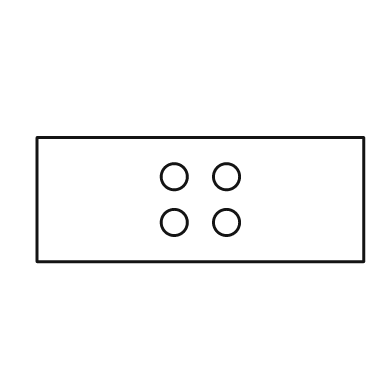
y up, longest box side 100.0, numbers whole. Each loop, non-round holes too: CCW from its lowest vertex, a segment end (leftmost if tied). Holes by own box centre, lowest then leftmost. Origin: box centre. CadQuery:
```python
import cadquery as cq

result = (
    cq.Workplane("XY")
    .moveTo(-50.0, -19.0)
    .lineTo(50.0, -19.0)
    .lineTo(50.0, 19.0)
    .lineTo(-50.0, 19.0)
    .close()
    .moveTo(-8.0, -7.0)
    .circle(4.0)
    .moveTo(8.0, -7.0)
    .circle(4.0)
    .moveTo(-8.0, 7.0)
    .circle(4.0)
    .moveTo(8.0, 7.0)
    .circle(4.0)
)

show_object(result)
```